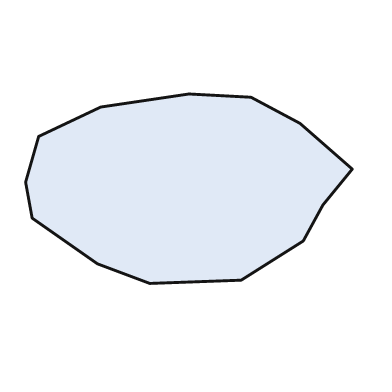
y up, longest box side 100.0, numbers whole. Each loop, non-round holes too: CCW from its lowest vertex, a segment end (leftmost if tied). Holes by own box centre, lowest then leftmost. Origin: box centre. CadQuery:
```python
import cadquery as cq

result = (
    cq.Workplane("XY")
    .moveTo(-12.0, -29.0)
    .lineTo(16.0, -28.0)
    .lineTo(35.0, -16.0)
    .lineTo(41.0, -5.0)
    .lineTo(50.0, 6.0)
    .lineTo(34.0, 20.0)
    .lineTo(19.0, 28.0)
    .lineTo(0.0, 29.0)
    .lineTo(-27.0, 25.0)
    .lineTo(-46.0, 16.0)
    .lineTo(-50.0, 2.0)
    .lineTo(-48.0, -9.0)
    .lineTo(-28.0, -23.0)
    .close()
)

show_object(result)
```